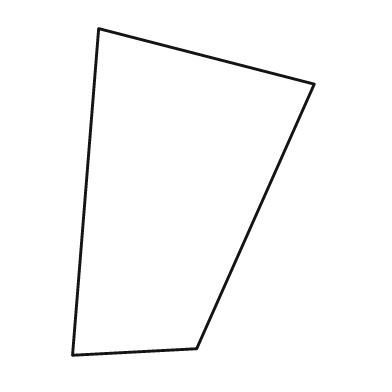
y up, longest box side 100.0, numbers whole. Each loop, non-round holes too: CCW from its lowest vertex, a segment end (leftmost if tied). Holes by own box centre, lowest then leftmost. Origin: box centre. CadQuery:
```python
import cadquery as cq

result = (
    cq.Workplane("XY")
    .moveTo(-37.0, -50.0)
    .lineTo(1.0, -48.0)
    .lineTo(37.0, 33.0)
    .lineTo(-29.0, 50.0)
    .close()
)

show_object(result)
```